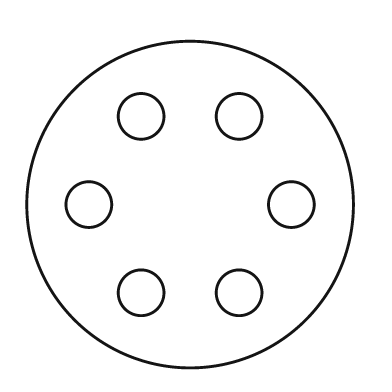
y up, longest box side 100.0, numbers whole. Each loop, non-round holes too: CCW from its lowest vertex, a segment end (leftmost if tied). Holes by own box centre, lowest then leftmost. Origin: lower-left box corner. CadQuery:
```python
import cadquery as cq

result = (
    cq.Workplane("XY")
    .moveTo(50.0, 50.0)
    .circle(50.0)
    .moveTo(35.0, 23.0)
    .circle(7.0)
    .moveTo(65.0, 23.0)
    .circle(7.0)
    .moveTo(19.0, 50.0)
    .circle(7.0)
    .moveTo(81.0, 50.0)
    .circle(7.0)
    .moveTo(35.0, 77.0)
    .circle(7.0)
    .moveTo(65.0, 77.0)
    .circle(7.0)
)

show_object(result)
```